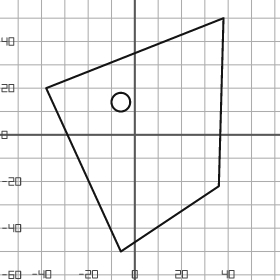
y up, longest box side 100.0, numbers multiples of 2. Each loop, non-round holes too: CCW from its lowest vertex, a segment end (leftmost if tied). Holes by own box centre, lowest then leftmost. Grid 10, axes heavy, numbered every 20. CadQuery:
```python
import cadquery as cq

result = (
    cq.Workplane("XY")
    .moveTo(-6.0, -50.0)
    .lineTo(36.0, -22.0)
    .lineTo(38.0, 50.0)
    .lineTo(-38.0, 20.0)
    .close()
    .moveTo(-6.0, 14.0)
    .circle(4.0)
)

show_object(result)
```